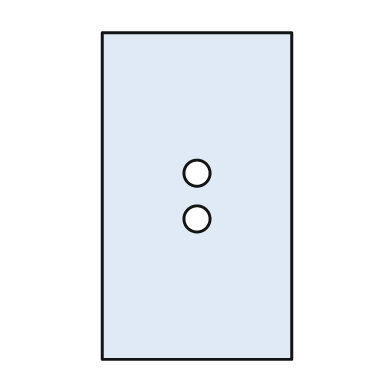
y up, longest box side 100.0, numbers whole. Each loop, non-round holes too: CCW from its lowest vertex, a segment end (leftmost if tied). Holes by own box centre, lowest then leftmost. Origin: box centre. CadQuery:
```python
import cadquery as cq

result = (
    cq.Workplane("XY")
    .moveTo(-29.0, -50.0)
    .lineTo(29.0, -50.0)
    .lineTo(29.0, 50.0)
    .lineTo(-29.0, 50.0)
    .close()
    .moveTo(0.0, -7.0)
    .circle(4.0)
    .moveTo(0.0, 7.0)
    .circle(4.0)
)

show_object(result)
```